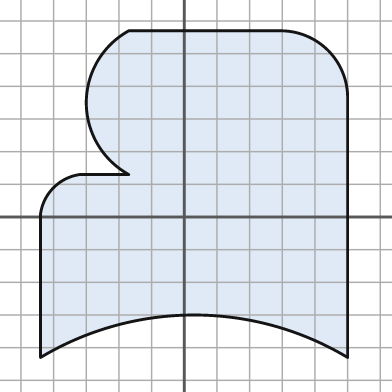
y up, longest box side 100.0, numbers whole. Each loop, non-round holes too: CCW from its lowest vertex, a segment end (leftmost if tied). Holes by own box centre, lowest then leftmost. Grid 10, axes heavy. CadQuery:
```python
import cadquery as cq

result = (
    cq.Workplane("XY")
    .moveTo(-44.0, -43.0)
    .threePointArc((3.0, -30.0), (50.0, -43.0))
    .lineTo(50.0, 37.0)
    .threePointArc((44.0, 51.0), (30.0, 57.0))
    .lineTo(-17.0, 57.0)
    .threePointArc((-30.0, 35.0), (-17.0, 13.0))
    .lineTo(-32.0, 13.0)
    .threePointArc((-40.0, 9.0), (-44.0, 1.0))
    .close()
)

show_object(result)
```